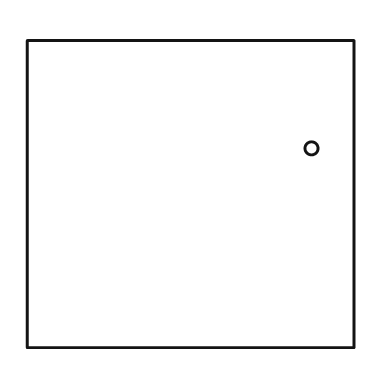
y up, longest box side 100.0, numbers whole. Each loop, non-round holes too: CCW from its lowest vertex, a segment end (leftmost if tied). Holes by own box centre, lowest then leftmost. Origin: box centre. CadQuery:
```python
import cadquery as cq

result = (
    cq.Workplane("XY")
    .moveTo(-50.0, -47.0)
    .lineTo(50.0, -47.0)
    .lineTo(50.0, 47.0)
    .lineTo(-50.0, 47.0)
    .close()
    .moveTo(37.0, 14.0)
    .circle(2.0)
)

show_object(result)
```